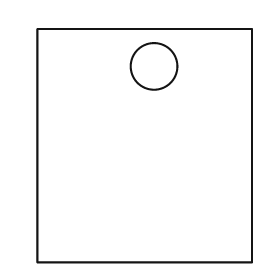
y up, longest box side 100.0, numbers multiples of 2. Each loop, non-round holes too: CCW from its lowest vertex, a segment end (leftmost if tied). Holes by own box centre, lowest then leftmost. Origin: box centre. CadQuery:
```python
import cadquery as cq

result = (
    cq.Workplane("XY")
    .moveTo(-46.0, -50.0)
    .lineTo(46.0, -50.0)
    .lineTo(46.0, 50.0)
    .lineTo(-46.0, 50.0)
    .close()
    .moveTo(4.0, 34.0)
    .circle(10.0)
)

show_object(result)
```